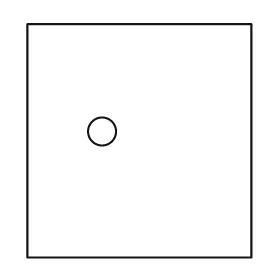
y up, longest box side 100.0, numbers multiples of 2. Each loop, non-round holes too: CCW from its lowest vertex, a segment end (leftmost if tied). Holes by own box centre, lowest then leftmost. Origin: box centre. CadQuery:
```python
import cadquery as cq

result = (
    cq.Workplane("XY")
    .moveTo(-48.0, -50.0)
    .lineTo(48.0, -50.0)
    .lineTo(48.0, 50.0)
    .lineTo(-48.0, 50.0)
    .close()
    .moveTo(-16.0, 4.0)
    .circle(6.0)
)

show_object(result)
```